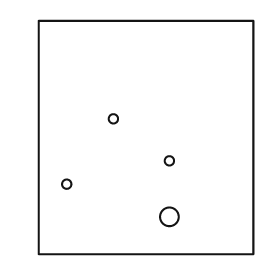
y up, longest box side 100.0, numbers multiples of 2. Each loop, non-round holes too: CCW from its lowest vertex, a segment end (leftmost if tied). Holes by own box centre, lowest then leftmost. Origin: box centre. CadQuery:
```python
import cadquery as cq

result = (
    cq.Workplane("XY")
    .moveTo(-46.0, -50.0)
    .lineTo(46.0, -50.0)
    .lineTo(46.0, 50.0)
    .lineTo(-46.0, 50.0)
    .close()
    .moveTo(10.0, -34.0)
    .circle(4.0)
    .moveTo(-34.0, -20.0)
    .circle(2.0)
    .moveTo(10.0, -10.0)
    .circle(2.0)
    .moveTo(-14.0, 8.0)
    .circle(2.0)
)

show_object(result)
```